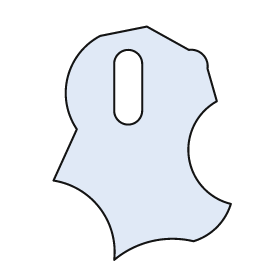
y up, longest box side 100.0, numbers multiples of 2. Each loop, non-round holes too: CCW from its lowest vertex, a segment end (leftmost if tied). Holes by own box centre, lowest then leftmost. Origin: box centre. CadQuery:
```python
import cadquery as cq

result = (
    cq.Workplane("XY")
    .moveTo(-12.0, -50.0)
    .threePointArc((4.0, -42.0), (22.0, -42.0))
    .threePointArc((32.0, -36.0), (38.0, -26.0))
    .threePointArc((20.0, -6.0), (32.0, 18.0))
    .lineTo(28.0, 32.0)
    .threePointArc((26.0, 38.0), (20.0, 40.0))
    .lineTo(2.0, 50.0)
    .lineTo(-18.0, 46.0)
    .threePointArc((-32.0, 28.0), (-28.0, 6.0))
    .lineTo(-38.0, -16.0)
    .threePointArc((-18.0, -28.0), (-12.0, -50.0))
    .close()
    .moveTo(-12.0, 14.0)
    .threePointArc((-6.0, 8.0), (0.0, 14.0))
    .lineTo(0.0, 34.0)
    .threePointArc((-6.0, 40.0), (-12.0, 34.0))
    .close()
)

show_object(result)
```